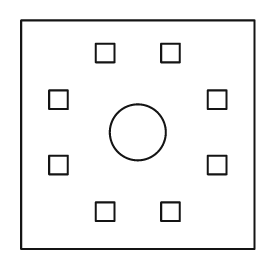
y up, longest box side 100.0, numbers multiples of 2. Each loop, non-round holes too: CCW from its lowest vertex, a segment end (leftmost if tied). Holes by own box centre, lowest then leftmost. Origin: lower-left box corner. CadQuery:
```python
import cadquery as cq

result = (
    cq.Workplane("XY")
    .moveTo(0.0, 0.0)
    .lineTo(100.0, 0.0)
    .lineTo(100.0, 98.0)
    .lineTo(0.0, 98.0)
    .close()
    .moveTo(32.0, 12.0)
    .lineTo(40.0, 12.0)
    .lineTo(40.0, 20.0)
    .lineTo(32.0, 20.0)
    .close()
    .moveTo(60.0, 12.0)
    .lineTo(68.0, 12.0)
    .lineTo(68.0, 20.0)
    .lineTo(60.0, 20.0)
    .close()
    .moveTo(12.0, 32.0)
    .lineTo(20.0, 32.0)
    .lineTo(20.0, 40.0)
    .lineTo(12.0, 40.0)
    .close()
    .moveTo(80.0, 32.0)
    .lineTo(88.0, 32.0)
    .lineTo(88.0, 40.0)
    .lineTo(80.0, 40.0)
    .close()
    .moveTo(50.0, 50.0)
    .circle(12.0)
    .moveTo(12.0, 60.0)
    .lineTo(20.0, 60.0)
    .lineTo(20.0, 68.0)
    .lineTo(12.0, 68.0)
    .close()
    .moveTo(80.0, 60.0)
    .lineTo(88.0, 60.0)
    .lineTo(88.0, 68.0)
    .lineTo(80.0, 68.0)
    .close()
    .moveTo(32.0, 80.0)
    .lineTo(40.0, 80.0)
    .lineTo(40.0, 88.0)
    .lineTo(32.0, 88.0)
    .close()
    .moveTo(60.0, 80.0)
    .lineTo(68.0, 80.0)
    .lineTo(68.0, 88.0)
    .lineTo(60.0, 88.0)
    .close()
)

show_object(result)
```